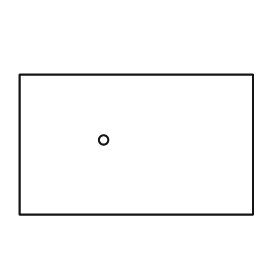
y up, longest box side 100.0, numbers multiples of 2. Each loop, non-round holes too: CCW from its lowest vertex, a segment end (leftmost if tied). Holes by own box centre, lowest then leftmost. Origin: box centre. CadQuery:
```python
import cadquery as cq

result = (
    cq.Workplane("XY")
    .moveTo(-50.0, -30.0)
    .lineTo(50.0, -30.0)
    .lineTo(50.0, 30.0)
    .lineTo(-50.0, 30.0)
    .close()
    .moveTo(-14.0, 2.0)
    .circle(2.0)
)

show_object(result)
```